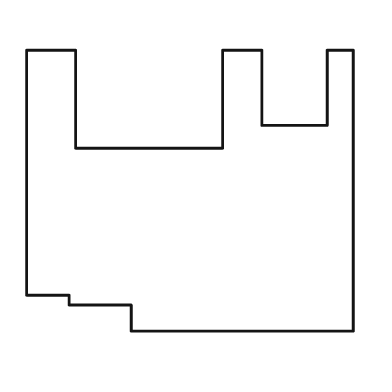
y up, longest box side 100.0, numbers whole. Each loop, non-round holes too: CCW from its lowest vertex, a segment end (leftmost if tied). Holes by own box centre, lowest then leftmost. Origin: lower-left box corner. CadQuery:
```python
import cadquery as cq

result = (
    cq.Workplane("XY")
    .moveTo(32.0, 0.0)
    .lineTo(100.0, 0.0)
    .lineTo(100.0, 86.0)
    .lineTo(92.0, 86.0)
    .lineTo(92.0, 63.0)
    .lineTo(72.0, 63.0)
    .lineTo(72.0, 86.0)
    .lineTo(60.0, 86.0)
    .lineTo(60.0, 56.0)
    .lineTo(15.0, 56.0)
    .lineTo(15.0, 86.0)
    .lineTo(0.0, 86.0)
    .lineTo(0.0, 11.0)
    .lineTo(13.0, 11.0)
    .lineTo(13.0, 8.0)
    .lineTo(32.0, 8.0)
    .close()
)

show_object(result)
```